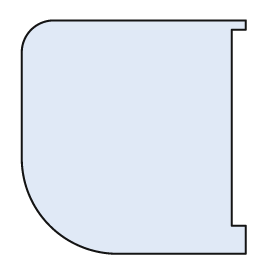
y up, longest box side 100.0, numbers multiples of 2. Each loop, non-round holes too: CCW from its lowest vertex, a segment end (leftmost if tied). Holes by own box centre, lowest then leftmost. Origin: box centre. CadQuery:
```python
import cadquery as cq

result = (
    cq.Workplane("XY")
    .moveTo(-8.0, -50.0)
    .lineTo(48.0, -50.0)
    .lineTo(48.0, -38.0)
    .lineTo(42.0, -38.0)
    .lineTo(42.0, 46.0)
    .lineTo(48.0, 46.0)
    .lineTo(48.0, 50.0)
    .lineTo(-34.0, 50.0)
    .threePointArc((-44.0, 46.0), (-48.0, 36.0))
    .lineTo(-48.0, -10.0)
    .threePointArc((-36.0, -38.0), (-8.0, -50.0))
    .close()
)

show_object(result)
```